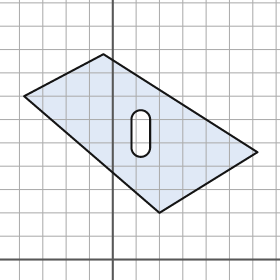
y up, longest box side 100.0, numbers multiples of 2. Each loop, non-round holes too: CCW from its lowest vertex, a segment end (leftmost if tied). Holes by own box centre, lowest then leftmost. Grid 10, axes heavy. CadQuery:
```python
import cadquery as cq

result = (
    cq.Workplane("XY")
    .moveTo(20.0, 20.0)
    .lineTo(62.0, 46.0)
    .lineTo(-4.0, 88.0)
    .lineTo(-38.0, 70.0)
    .close()
    .moveTo(8.0, 48.0)
    .threePointArc((12.0, 44.0), (16.0, 48.0))
    .lineTo(16.0, 60.0)
    .threePointArc((12.0, 64.0), (8.0, 60.0))
    .close()
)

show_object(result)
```